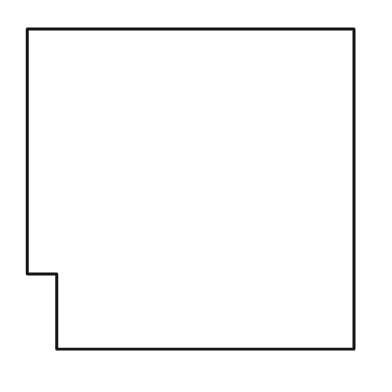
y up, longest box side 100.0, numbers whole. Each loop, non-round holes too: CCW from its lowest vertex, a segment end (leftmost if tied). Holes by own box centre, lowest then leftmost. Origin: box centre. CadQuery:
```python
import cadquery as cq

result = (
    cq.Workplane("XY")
    .moveTo(-41.0, -49.0)
    .lineTo(50.0, -49.0)
    .lineTo(50.0, 49.0)
    .lineTo(-50.0, 49.0)
    .lineTo(-50.0, -26.0)
    .lineTo(-41.0, -26.0)
    .close()
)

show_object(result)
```